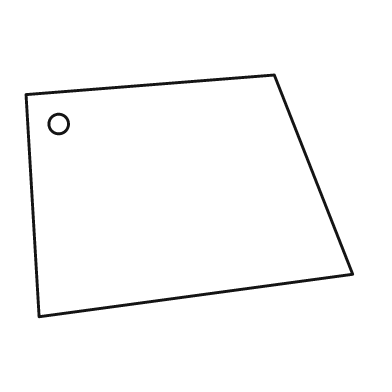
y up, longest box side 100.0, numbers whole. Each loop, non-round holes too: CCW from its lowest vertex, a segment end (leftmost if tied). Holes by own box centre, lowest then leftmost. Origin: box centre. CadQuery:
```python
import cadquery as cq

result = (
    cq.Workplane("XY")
    .moveTo(-46.0, -37.0)
    .lineTo(50.0, -24.0)
    .lineTo(26.0, 37.0)
    .lineTo(-50.0, 31.0)
    .close()
    .moveTo(-40.0, 22.0)
    .circle(3.0)
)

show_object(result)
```